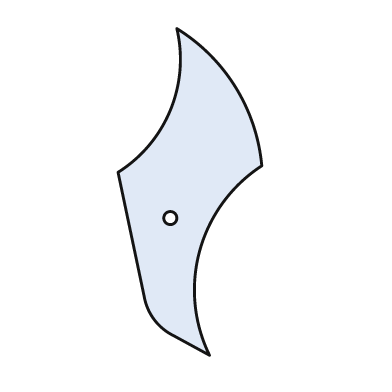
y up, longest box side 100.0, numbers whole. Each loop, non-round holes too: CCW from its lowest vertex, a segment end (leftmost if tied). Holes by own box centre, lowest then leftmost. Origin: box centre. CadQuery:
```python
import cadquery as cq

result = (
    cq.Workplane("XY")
    .moveTo(6.0, -50.0)
    .threePointArc((3.0, -18.0), (22.0, 8.0))
    .threePointArc((14.0, 32.0), (-4.0, 50.0))
    .threePointArc((-6.0, 25.0), (-22.0, 6.0))
    .lineTo(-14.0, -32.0)
    .threePointArc((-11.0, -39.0), (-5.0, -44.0))
    .close()
    .moveTo(-6.0, -8.0)
    .circle(2.0)
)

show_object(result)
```